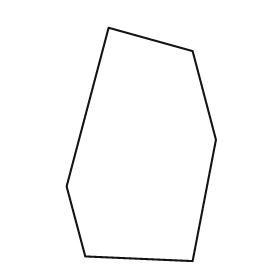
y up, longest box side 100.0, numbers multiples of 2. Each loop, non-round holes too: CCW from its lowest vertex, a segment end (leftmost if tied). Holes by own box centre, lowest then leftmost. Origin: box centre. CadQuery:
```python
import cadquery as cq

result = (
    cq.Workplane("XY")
    .moveTo(22.0, -50.0)
    .lineTo(32.0, 2.0)
    .lineTo(22.0, 40.0)
    .lineTo(-14.0, 50.0)
    .lineTo(-32.0, -18.0)
    .lineTo(-24.0, -48.0)
    .close()
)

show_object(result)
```